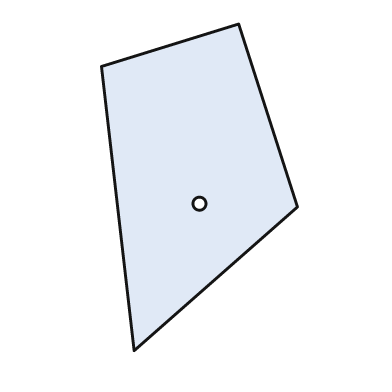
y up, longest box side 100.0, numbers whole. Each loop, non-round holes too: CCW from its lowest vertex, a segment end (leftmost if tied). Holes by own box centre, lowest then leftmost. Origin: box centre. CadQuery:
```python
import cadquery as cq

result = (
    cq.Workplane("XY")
    .moveTo(-20.0, -50.0)
    .lineTo(30.0, -6.0)
    .lineTo(12.0, 50.0)
    .lineTo(-30.0, 37.0)
    .close()
    .moveTo(0.0, -5.0)
    .circle(2.0)
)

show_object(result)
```